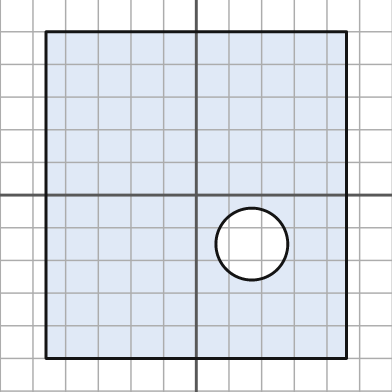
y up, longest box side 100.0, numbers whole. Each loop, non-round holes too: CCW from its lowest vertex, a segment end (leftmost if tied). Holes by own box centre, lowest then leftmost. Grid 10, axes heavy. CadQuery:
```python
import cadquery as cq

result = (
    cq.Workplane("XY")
    .moveTo(-46.0, -50.0)
    .lineTo(46.0, -50.0)
    .lineTo(46.0, 50.0)
    .lineTo(-46.0, 50.0)
    .close()
    .moveTo(17.0, -15.0)
    .circle(11.0)
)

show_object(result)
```